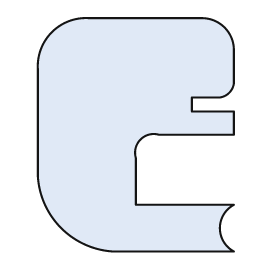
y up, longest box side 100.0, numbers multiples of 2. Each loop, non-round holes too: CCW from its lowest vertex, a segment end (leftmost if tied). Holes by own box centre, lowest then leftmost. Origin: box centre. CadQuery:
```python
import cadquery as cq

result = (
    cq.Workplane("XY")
    .moveTo(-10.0, -50.0)
    .lineTo(42.0, -50.0)
    .threePointArc((36.0, -40.0), (42.0, -30.0))
    .lineTo(0.0, -30.0)
    .lineTo(0.0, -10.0)
    .threePointArc((2.0, -2.0), (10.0, 0.0))
    .lineTo(42.0, 0.0)
    .lineTo(42.0, 10.0)
    .lineTo(24.0, 10.0)
    .lineTo(24.0, 16.0)
    .lineTo(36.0, 16.0)
    .threePointArc((40.0, 18.0), (42.0, 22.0))
    .lineTo(42.0, 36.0)
    .threePointArc((38.0, 46.0), (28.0, 50.0))
    .lineTo(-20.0, 50.0)
    .threePointArc((-36.0, 44.0), (-42.0, 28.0))
    .lineTo(-42.0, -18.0)
    .threePointArc((-32.0, -40.0), (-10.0, -50.0))
    .close()
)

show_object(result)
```